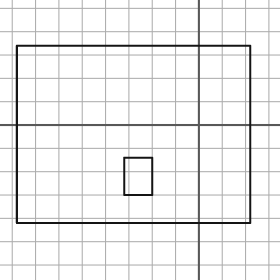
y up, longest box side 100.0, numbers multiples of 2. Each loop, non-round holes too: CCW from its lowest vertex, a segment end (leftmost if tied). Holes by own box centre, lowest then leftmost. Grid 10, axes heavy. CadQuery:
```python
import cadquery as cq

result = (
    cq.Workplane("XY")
    .moveTo(-78.0, -42.0)
    .lineTo(22.0, -42.0)
    .lineTo(22.0, 34.0)
    .lineTo(-78.0, 34.0)
    .close()
    .moveTo(-32.0, -30.0)
    .lineTo(-20.0, -30.0)
    .lineTo(-20.0, -14.0)
    .lineTo(-32.0, -14.0)
    .close()
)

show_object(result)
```